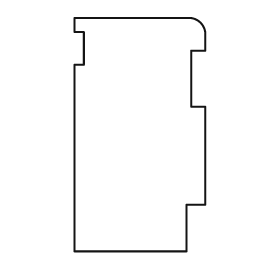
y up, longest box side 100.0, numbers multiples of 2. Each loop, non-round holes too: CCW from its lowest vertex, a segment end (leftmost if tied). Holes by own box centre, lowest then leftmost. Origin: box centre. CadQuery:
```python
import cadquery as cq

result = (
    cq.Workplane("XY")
    .moveTo(-28.0, -50.0)
    .lineTo(20.0, -50.0)
    .lineTo(20.0, -30.0)
    .lineTo(28.0, -30.0)
    .lineTo(28.0, 12.0)
    .lineTo(22.0, 12.0)
    .lineTo(22.0, 36.0)
    .lineTo(28.0, 36.0)
    .lineTo(28.0, 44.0)
    .threePointArc((26.0, 48.0), (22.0, 50.0))
    .lineTo(-28.0, 50.0)
    .lineTo(-28.0, 44.0)
    .lineTo(-24.0, 44.0)
    .lineTo(-24.0, 30.0)
    .lineTo(-28.0, 30.0)
    .close()
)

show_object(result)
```